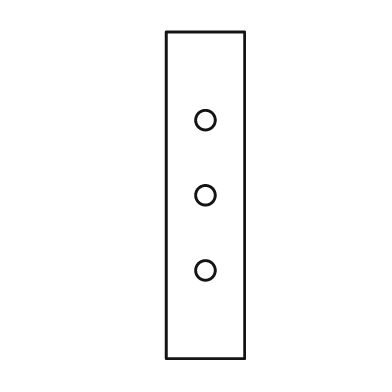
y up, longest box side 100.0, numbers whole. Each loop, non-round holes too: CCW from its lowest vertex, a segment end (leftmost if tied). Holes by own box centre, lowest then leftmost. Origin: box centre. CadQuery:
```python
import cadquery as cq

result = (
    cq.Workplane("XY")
    .moveTo(-12.0, -50.0)
    .lineTo(12.0, -50.0)
    .lineTo(12.0, 50.0)
    .lineTo(-12.0, 50.0)
    .close()
    .moveTo(0.0, -23.0)
    .circle(3.0)
    .moveTo(0.0, 0.0)
    .circle(3.0)
    .moveTo(0.0, 23.0)
    .circle(3.0)
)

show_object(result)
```